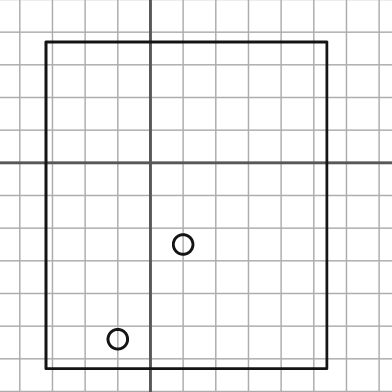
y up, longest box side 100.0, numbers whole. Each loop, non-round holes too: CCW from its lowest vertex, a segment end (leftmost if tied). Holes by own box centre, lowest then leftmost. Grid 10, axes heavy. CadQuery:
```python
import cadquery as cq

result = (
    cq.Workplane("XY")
    .moveTo(-32.0, -63.0)
    .lineTo(54.0, -63.0)
    .lineTo(54.0, 37.0)
    .lineTo(-32.0, 37.0)
    .close()
    .moveTo(-10.0, -54.0)
    .circle(3.0)
    .moveTo(10.0, -25.0)
    .circle(3.0)
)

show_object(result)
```